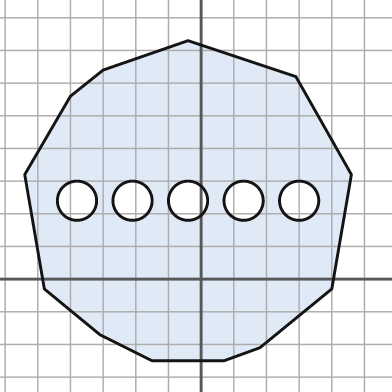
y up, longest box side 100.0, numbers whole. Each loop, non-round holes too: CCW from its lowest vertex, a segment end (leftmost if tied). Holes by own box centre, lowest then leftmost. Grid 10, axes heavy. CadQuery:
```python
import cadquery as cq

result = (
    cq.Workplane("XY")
    .moveTo(-15.0, -25.0)
    .lineTo(7.0, -25.0)
    .lineTo(18.0, -21.0)
    .lineTo(40.0, -3.0)
    .lineTo(46.0, 32.0)
    .lineTo(29.0, 62.0)
    .lineTo(-4.0, 73.0)
    .lineTo(-30.0, 64.0)
    .lineTo(-40.0, 56.0)
    .lineTo(-54.0, 32.0)
    .lineTo(-48.0, -3.0)
    .lineTo(-31.0, -17.0)
    .close()
    .moveTo(-38.0, 24.0)
    .circle(6.0)
    .moveTo(-21.0, 24.0)
    .circle(6.0)
    .moveTo(-4.0, 24.0)
    .circle(6.0)
    .moveTo(13.0, 24.0)
    .circle(6.0)
    .moveTo(30.0, 24.0)
    .circle(6.0)
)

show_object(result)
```